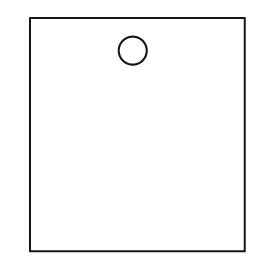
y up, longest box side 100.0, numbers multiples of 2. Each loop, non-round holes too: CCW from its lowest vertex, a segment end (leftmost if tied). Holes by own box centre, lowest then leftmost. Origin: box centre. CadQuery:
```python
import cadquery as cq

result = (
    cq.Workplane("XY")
    .moveTo(-46.0, -50.0)
    .lineTo(46.0, -50.0)
    .lineTo(46.0, 50.0)
    .lineTo(-46.0, 50.0)
    .close()
    .moveTo(-2.0, 36.0)
    .circle(6.0)
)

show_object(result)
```